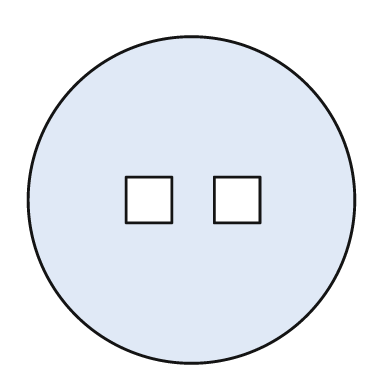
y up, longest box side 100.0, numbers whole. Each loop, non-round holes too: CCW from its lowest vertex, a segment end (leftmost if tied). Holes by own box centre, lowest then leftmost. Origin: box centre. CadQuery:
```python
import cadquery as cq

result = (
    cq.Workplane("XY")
    .moveTo(0.0, 0.0)
    .circle(50.0)
    .moveTo(-20.0, -7.0)
    .lineTo(-6.0, -7.0)
    .lineTo(-6.0, 7.0)
    .lineTo(-20.0, 7.0)
    .close()
    .moveTo(7.0, -7.0)
    .lineTo(21.0, -7.0)
    .lineTo(21.0, 7.0)
    .lineTo(7.0, 7.0)
    .close()
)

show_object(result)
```